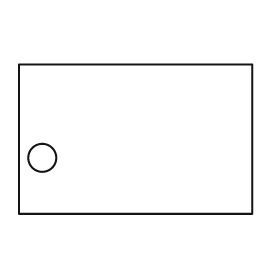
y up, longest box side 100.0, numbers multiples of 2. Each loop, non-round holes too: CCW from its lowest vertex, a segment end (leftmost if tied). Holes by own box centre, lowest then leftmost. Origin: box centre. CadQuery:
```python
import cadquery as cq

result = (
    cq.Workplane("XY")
    .moveTo(-50.0, -32.0)
    .lineTo(50.0, -32.0)
    .lineTo(50.0, 32.0)
    .lineTo(-50.0, 32.0)
    .close()
    .moveTo(-40.0, -8.0)
    .circle(6.0)
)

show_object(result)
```